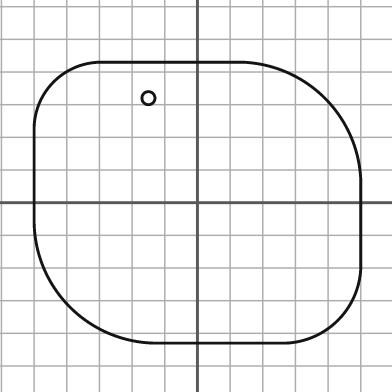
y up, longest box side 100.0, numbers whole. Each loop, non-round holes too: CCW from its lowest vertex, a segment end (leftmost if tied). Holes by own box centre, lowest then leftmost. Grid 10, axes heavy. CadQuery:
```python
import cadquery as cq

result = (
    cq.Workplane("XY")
    .moveTo(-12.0, -43.0)
    .lineTo(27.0, -43.0)
    .threePointArc((43.0, -36.0), (50.0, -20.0))
    .lineTo(50.0, 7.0)
    .threePointArc((39.0, 32.0), (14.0, 43.0))
    .lineTo(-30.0, 43.0)
    .threePointArc((-44.0, 37.0), (-50.0, 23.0))
    .lineTo(-50.0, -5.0)
    .threePointArc((-39.0, -32.0), (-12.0, -43.0))
    .close()
    .moveTo(-15.0, 32.0)
    .circle(2.0)
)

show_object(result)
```